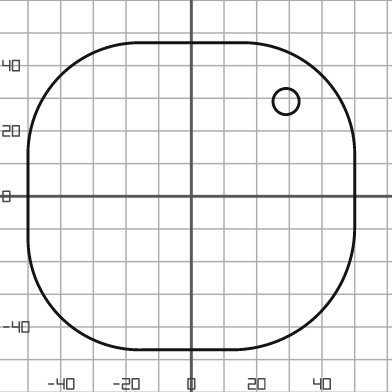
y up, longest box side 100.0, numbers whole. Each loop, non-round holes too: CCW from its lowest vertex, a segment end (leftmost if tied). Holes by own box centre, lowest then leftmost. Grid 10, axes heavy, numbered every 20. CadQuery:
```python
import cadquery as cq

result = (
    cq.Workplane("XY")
    .moveTo(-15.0, -47.0)
    .lineTo(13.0, -47.0)
    .threePointArc((39.0, -36.0), (50.0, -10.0))
    .lineTo(50.0, 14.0)
    .threePointArc((40.0, 37.0), (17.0, 47.0))
    .lineTo(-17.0, 47.0)
    .threePointArc((-40.0, 37.0), (-50.0, 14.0))
    .lineTo(-50.0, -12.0)
    .threePointArc((-40.0, -37.0), (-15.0, -47.0))
    .close()
    .moveTo(29.0, 29.0)
    .circle(4.0)
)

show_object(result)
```